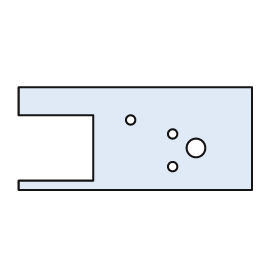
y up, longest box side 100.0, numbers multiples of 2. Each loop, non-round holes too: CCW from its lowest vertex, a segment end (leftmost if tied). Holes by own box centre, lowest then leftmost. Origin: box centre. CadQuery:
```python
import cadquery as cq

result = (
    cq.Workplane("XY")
    .moveTo(-50.0, -22.0)
    .lineTo(50.0, -22.0)
    .lineTo(50.0, 22.0)
    .lineTo(-50.0, 22.0)
    .lineTo(-50.0, 10.0)
    .lineTo(-18.0, 10.0)
    .lineTo(-18.0, -18.0)
    .lineTo(-50.0, -18.0)
    .close()
    .moveTo(16.0, -12.0)
    .circle(2.0)
    .moveTo(26.0, -4.0)
    .circle(4.0)
    .moveTo(16.0, 2.0)
    .circle(2.0)
    .moveTo(-2.0, 8.0)
    .circle(2.0)
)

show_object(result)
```